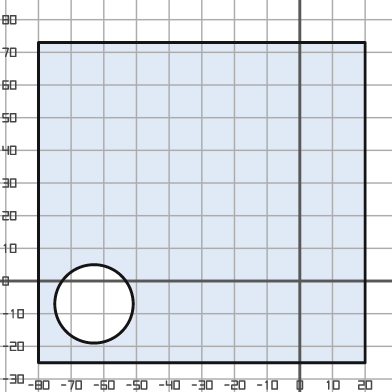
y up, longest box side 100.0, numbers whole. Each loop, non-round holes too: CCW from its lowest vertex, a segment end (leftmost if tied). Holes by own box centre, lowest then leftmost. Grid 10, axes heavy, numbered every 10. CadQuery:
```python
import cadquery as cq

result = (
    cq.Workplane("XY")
    .moveTo(-80.0, -25.0)
    .lineTo(20.0, -25.0)
    .lineTo(20.0, 73.0)
    .lineTo(-80.0, 73.0)
    .close()
    .moveTo(-63.0, -7.0)
    .circle(12.0)
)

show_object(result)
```